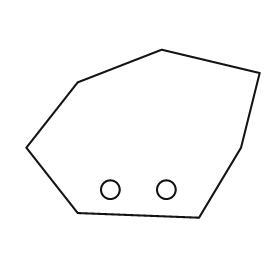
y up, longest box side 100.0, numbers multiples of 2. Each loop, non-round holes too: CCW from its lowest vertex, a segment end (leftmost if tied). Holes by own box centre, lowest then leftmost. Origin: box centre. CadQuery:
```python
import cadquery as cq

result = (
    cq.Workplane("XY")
    .moveTo(24.0, -36.0)
    .lineTo(42.0, -6.0)
    .lineTo(50.0, 26.0)
    .lineTo(8.0, 36.0)
    .lineTo(-28.0, 22.0)
    .lineTo(-50.0, -6.0)
    .lineTo(-28.0, -34.0)
    .close()
    .moveTo(-14.0, -24.0)
    .circle(4.0)
    .moveTo(10.0, -24.0)
    .circle(4.0)
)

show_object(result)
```